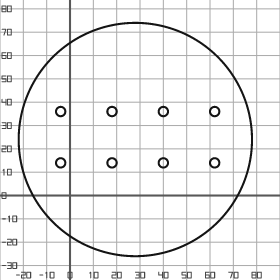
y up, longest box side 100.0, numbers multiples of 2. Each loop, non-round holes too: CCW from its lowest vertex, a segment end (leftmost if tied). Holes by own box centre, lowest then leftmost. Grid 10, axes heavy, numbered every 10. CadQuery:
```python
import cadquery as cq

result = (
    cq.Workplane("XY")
    .moveTo(28.0, 24.0)
    .circle(50.0)
    .moveTo(-4.0, 14.0)
    .circle(2.0)
    .moveTo(18.0, 14.0)
    .circle(2.0)
    .moveTo(40.0, 14.0)
    .circle(2.0)
    .moveTo(62.0, 14.0)
    .circle(2.0)
    .moveTo(-4.0, 36.0)
    .circle(2.0)
    .moveTo(18.0, 36.0)
    .circle(2.0)
    .moveTo(40.0, 36.0)
    .circle(2.0)
    .moveTo(62.0, 36.0)
    .circle(2.0)
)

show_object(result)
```